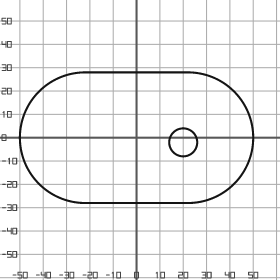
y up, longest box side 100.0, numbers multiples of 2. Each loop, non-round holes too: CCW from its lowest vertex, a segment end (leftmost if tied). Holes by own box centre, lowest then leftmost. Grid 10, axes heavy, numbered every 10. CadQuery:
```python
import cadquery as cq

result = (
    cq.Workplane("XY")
    .moveTo(-22.0, -28.0)
    .lineTo(22.0, -28.0)
    .threePointArc((50.0, 0.0), (22.0, 28.0))
    .lineTo(-22.0, 28.0)
    .threePointArc((-50.0, 0.0), (-22.0, -28.0))
    .close()
    .moveTo(20.0, -2.0)
    .circle(6.0)
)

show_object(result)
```